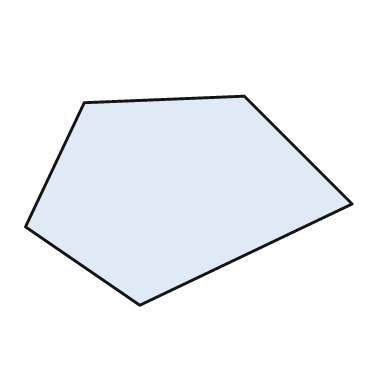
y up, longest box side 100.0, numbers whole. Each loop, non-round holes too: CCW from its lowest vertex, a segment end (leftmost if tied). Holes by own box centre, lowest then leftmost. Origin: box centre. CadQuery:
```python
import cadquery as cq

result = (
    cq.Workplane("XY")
    .moveTo(-15.0, -32.0)
    .lineTo(50.0, -1.0)
    .lineTo(17.0, 32.0)
    .lineTo(-32.0, 30.0)
    .lineTo(-50.0, -8.0)
    .close()
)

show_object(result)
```